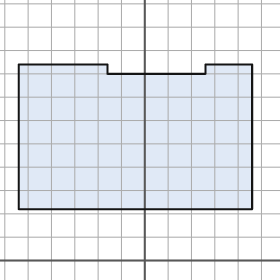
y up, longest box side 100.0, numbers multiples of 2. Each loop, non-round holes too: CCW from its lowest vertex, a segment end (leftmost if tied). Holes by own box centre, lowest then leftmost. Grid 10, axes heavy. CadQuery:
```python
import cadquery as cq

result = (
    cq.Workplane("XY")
    .moveTo(-54.0, 22.0)
    .lineTo(46.0, 22.0)
    .lineTo(46.0, 84.0)
    .lineTo(26.0, 84.0)
    .lineTo(26.0, 80.0)
    .lineTo(-16.0, 80.0)
    .lineTo(-16.0, 84.0)
    .lineTo(-54.0, 84.0)
    .close()
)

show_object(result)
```